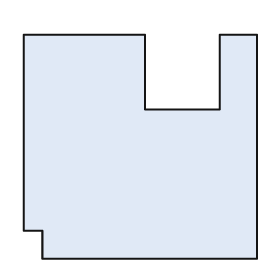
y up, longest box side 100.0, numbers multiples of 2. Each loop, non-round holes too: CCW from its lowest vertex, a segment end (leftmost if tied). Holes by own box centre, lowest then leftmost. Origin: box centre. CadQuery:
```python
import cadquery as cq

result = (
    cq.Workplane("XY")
    .moveTo(-42.0, -48.0)
    .lineTo(50.0, -48.0)
    .lineTo(50.0, 48.0)
    .lineTo(34.0, 48.0)
    .lineTo(34.0, 16.0)
    .lineTo(2.0, 16.0)
    .lineTo(2.0, 48.0)
    .lineTo(-50.0, 48.0)
    .lineTo(-50.0, -36.0)
    .lineTo(-42.0, -36.0)
    .close()
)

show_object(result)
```